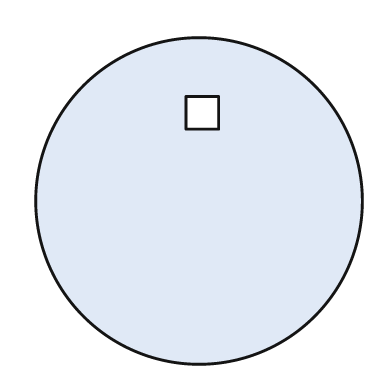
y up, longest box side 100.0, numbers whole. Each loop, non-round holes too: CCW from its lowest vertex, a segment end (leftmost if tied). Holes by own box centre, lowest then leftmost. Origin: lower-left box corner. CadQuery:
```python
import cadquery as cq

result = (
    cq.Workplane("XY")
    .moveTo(50.0, 50.0)
    .circle(50.0)
    .moveTo(46.0, 72.0)
    .lineTo(56.0, 72.0)
    .lineTo(56.0, 82.0)
    .lineTo(46.0, 82.0)
    .close()
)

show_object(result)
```